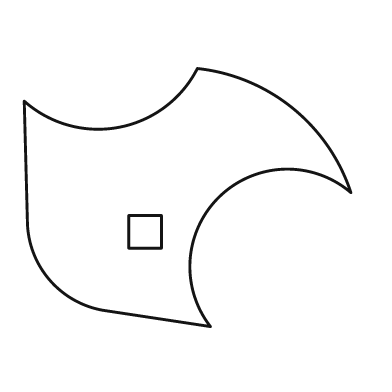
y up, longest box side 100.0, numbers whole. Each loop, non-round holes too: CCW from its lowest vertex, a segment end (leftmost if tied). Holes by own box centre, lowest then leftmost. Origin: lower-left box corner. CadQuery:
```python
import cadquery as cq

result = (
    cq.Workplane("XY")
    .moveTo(57.0, 0.0)
    .threePointArc((60.0, 40.0), (100.0, 41.0))
    .threePointArc((82.0, 67.0), (53.0, 79.0))
    .threePointArc((29.0, 61.0), (0.0, 69.0))
    .lineTo(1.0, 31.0)
    .threePointArc((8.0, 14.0), (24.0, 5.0))
    .close()
    .moveTo(32.0, 24.0)
    .lineTo(42.0, 24.0)
    .lineTo(42.0, 34.0)
    .lineTo(32.0, 34.0)
    .close()
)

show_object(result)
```